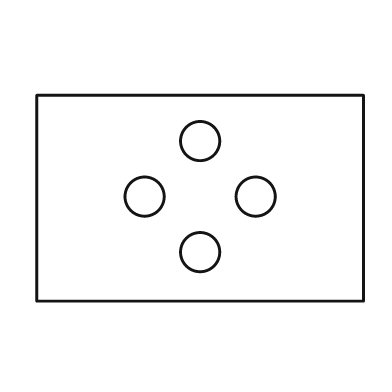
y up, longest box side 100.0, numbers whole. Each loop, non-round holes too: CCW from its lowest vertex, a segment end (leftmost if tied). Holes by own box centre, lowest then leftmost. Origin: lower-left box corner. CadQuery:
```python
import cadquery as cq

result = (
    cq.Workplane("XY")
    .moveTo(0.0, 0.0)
    .lineTo(100.0, 0.0)
    .lineTo(100.0, 63.0)
    .lineTo(0.0, 63.0)
    .close()
    .moveTo(50.0, 15.0)
    .circle(6.0)
    .moveTo(33.0, 32.0)
    .circle(6.0)
    .moveTo(67.0, 32.0)
    .circle(6.0)
    .moveTo(50.0, 49.0)
    .circle(6.0)
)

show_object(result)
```